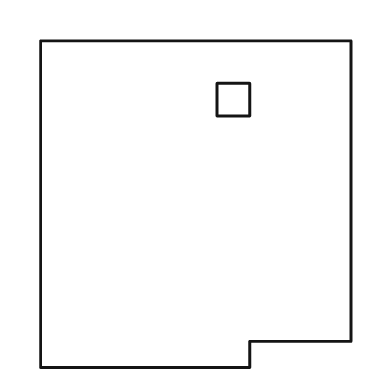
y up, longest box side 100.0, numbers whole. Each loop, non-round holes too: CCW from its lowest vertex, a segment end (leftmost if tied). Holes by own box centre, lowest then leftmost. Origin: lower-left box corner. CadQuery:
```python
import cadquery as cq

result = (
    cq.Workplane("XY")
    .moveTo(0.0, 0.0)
    .lineTo(64.0, 0.0)
    .lineTo(64.0, 8.0)
    .lineTo(95.0, 8.0)
    .lineTo(95.0, 100.0)
    .lineTo(0.0, 100.0)
    .close()
    .moveTo(54.0, 77.0)
    .lineTo(64.0, 77.0)
    .lineTo(64.0, 87.0)
    .lineTo(54.0, 87.0)
    .close()
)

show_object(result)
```